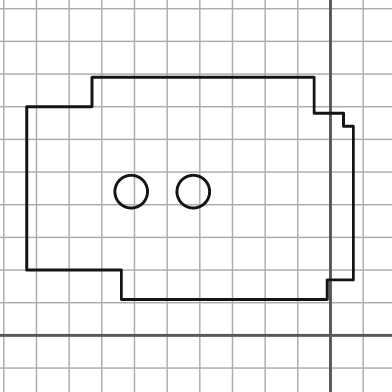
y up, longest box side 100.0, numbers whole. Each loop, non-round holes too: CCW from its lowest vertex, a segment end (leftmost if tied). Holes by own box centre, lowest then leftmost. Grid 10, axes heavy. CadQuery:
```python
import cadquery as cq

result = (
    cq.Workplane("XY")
    .moveTo(-64.0, 11.0)
    .lineTo(-1.0, 11.0)
    .lineTo(-1.0, 17.0)
    .lineTo(7.0, 17.0)
    .lineTo(7.0, 64.0)
    .lineTo(4.0, 64.0)
    .lineTo(4.0, 68.0)
    .lineTo(-5.0, 68.0)
    .lineTo(-5.0, 79.0)
    .lineTo(-73.0, 79.0)
    .lineTo(-73.0, 70.0)
    .lineTo(-93.0, 70.0)
    .lineTo(-93.0, 20.0)
    .lineTo(-64.0, 20.0)
    .close()
    .moveTo(-61.0, 44.0)
    .circle(5.0)
    .moveTo(-42.0, 44.0)
    .circle(5.0)
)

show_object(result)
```